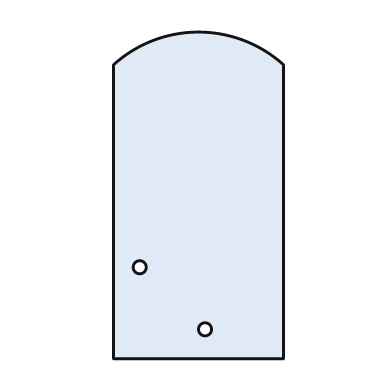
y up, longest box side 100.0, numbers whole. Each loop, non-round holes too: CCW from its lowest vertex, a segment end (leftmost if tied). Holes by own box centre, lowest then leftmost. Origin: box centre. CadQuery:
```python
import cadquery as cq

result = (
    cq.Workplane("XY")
    .moveTo(-26.0, -50.0)
    .lineTo(26.0, -50.0)
    .lineTo(26.0, 40.0)
    .threePointArc((0.0, 50.0), (-26.0, 40.0))
    .close()
    .moveTo(2.0, -41.0)
    .circle(2.0)
    .moveTo(-18.0, -22.0)
    .circle(2.0)
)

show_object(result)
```